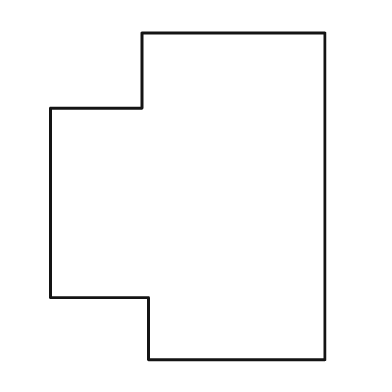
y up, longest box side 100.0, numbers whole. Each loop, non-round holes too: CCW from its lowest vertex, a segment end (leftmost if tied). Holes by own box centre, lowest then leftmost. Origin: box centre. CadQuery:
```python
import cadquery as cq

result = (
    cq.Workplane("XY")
    .moveTo(-12.0, -50.0)
    .lineTo(42.0, -50.0)
    .lineTo(42.0, 50.0)
    .lineTo(-14.0, 50.0)
    .lineTo(-14.0, 27.0)
    .lineTo(-42.0, 27.0)
    .lineTo(-42.0, -31.0)
    .lineTo(-12.0, -31.0)
    .close()
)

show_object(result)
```